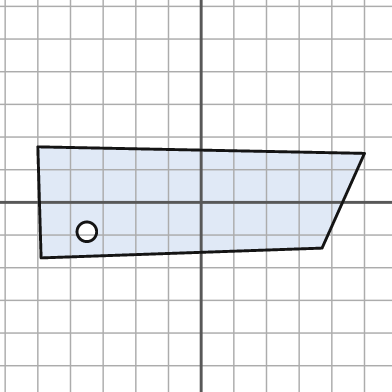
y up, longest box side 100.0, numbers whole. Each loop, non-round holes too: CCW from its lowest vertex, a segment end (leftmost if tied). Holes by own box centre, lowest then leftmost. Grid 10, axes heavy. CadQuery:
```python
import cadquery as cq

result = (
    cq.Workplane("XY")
    .moveTo(-49.0, -17.0)
    .lineTo(37.0, -14.0)
    .lineTo(50.0, 15.0)
    .lineTo(-50.0, 17.0)
    .close()
    .moveTo(-35.0, -9.0)
    .circle(3.0)
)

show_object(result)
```